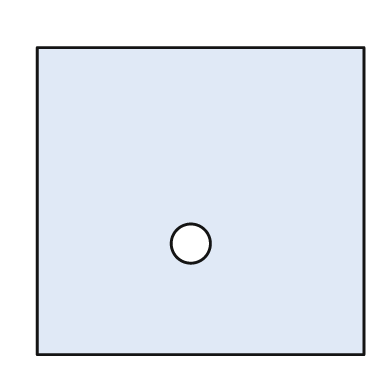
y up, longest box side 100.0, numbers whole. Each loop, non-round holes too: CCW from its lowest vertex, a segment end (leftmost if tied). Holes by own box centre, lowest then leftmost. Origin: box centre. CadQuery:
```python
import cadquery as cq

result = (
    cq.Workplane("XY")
    .moveTo(-50.0, -47.0)
    .lineTo(50.0, -47.0)
    .lineTo(50.0, 47.0)
    .lineTo(-50.0, 47.0)
    .close()
    .moveTo(-3.0, -13.0)
    .circle(6.0)
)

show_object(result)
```